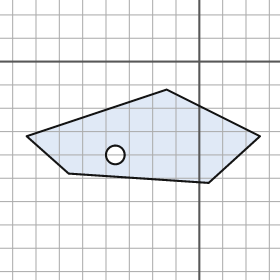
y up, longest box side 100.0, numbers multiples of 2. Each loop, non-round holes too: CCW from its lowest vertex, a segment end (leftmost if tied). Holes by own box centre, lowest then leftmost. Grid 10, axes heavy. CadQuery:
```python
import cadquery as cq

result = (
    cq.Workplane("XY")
    .moveTo(4.0, -52.0)
    .lineTo(26.0, -32.0)
    .lineTo(-14.0, -12.0)
    .lineTo(-74.0, -32.0)
    .lineTo(-56.0, -48.0)
    .close()
    .moveTo(-36.0, -40.0)
    .circle(4.0)
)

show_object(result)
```